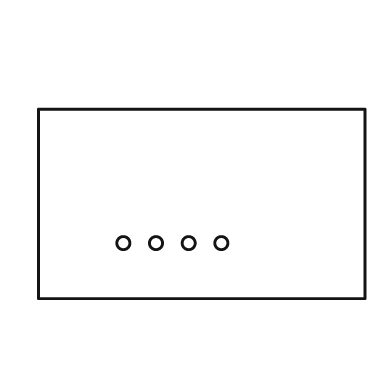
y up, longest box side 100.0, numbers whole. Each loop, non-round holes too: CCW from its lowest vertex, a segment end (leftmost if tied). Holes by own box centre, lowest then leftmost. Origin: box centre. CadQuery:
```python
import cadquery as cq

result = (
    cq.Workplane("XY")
    .moveTo(-50.0, -29.0)
    .lineTo(50.0, -29.0)
    .lineTo(50.0, 29.0)
    .lineTo(-50.0, 29.0)
    .close()
    .moveTo(-24.0, -12.0)
    .circle(2.0)
    .moveTo(-14.0, -12.0)
    .circle(2.0)
    .moveTo(-4.0, -12.0)
    .circle(2.0)
    .moveTo(6.0, -12.0)
    .circle(2.0)
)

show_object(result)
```